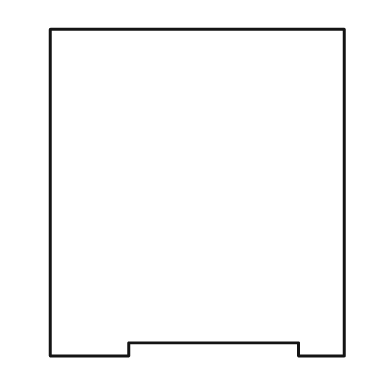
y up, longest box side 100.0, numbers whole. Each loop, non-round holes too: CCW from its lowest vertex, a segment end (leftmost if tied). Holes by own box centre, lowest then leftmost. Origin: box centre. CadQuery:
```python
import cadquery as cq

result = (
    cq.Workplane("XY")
    .moveTo(-45.0, -50.0)
    .lineTo(-21.0, -50.0)
    .lineTo(-21.0, -46.0)
    .lineTo(31.0, -46.0)
    .lineTo(31.0, -50.0)
    .lineTo(45.0, -50.0)
    .lineTo(45.0, 50.0)
    .lineTo(-45.0, 50.0)
    .close()
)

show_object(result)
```